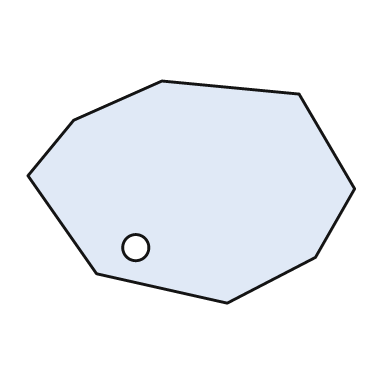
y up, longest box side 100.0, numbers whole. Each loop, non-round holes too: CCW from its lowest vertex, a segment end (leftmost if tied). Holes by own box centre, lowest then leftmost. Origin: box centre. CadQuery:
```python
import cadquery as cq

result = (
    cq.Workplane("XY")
    .moveTo(11.0, -34.0)
    .lineTo(38.0, -20.0)
    .lineTo(50.0, 1.0)
    .lineTo(33.0, 30.0)
    .lineTo(-9.0, 34.0)
    .lineTo(-36.0, 22.0)
    .lineTo(-50.0, 5.0)
    .lineTo(-29.0, -25.0)
    .close()
    .moveTo(-17.0, -17.0)
    .circle(4.0)
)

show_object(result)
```